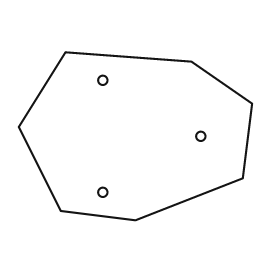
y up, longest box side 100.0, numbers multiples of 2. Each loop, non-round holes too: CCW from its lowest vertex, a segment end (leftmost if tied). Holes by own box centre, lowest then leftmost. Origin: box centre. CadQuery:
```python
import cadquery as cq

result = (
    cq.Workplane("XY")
    .moveTo(0.0, -36.0)
    .lineTo(46.0, -18.0)
    .lineTo(50.0, 14.0)
    .lineTo(24.0, 32.0)
    .lineTo(-30.0, 36.0)
    .lineTo(-50.0, 4.0)
    .lineTo(-32.0, -32.0)
    .close()
    .moveTo(-14.0, -24.0)
    .circle(2.0)
    .moveTo(28.0, 0.0)
    .circle(2.0)
    .moveTo(-14.0, 24.0)
    .circle(2.0)
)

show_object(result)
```